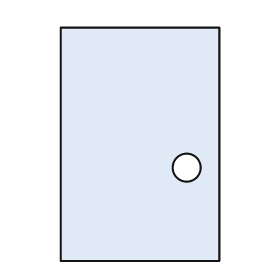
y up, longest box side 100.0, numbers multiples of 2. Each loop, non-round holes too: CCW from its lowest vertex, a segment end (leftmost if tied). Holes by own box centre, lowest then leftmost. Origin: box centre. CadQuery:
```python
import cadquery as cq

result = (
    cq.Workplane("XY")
    .moveTo(-34.0, -50.0)
    .lineTo(34.0, -50.0)
    .lineTo(34.0, 50.0)
    .lineTo(-34.0, 50.0)
    .close()
    .moveTo(20.0, -10.0)
    .circle(6.0)
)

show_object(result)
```